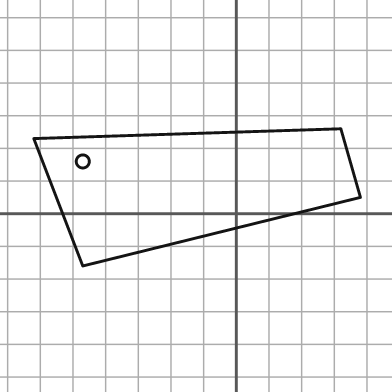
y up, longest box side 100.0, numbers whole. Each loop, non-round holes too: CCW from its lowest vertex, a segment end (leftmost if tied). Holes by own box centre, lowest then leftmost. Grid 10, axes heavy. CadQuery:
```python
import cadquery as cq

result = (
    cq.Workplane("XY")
    .moveTo(-47.0, -16.0)
    .lineTo(38.0, 5.0)
    .lineTo(32.0, 26.0)
    .lineTo(-62.0, 23.0)
    .close()
    .moveTo(-47.0, 16.0)
    .circle(2.0)
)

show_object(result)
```